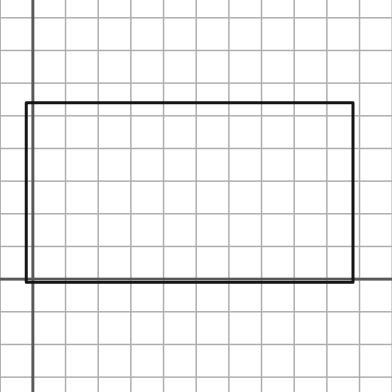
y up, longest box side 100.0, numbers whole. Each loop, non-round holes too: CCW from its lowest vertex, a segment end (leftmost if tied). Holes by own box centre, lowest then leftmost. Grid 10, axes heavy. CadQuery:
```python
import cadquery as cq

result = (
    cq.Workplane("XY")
    .moveTo(-2.0, -1.0)
    .lineTo(98.0, -1.0)
    .lineTo(98.0, 54.0)
    .lineTo(-2.0, 54.0)
    .close()
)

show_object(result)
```